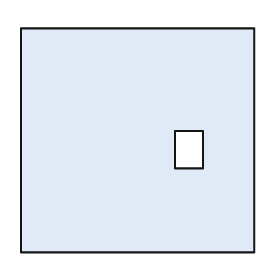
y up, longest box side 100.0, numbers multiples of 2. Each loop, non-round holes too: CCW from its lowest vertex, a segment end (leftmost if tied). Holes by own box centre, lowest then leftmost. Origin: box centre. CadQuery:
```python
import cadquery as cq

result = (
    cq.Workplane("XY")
    .moveTo(-50.0, -48.0)
    .lineTo(50.0, -48.0)
    .lineTo(50.0, 48.0)
    .lineTo(-50.0, 48.0)
    .close()
    .moveTo(16.0, -12.0)
    .lineTo(28.0, -12.0)
    .lineTo(28.0, 4.0)
    .lineTo(16.0, 4.0)
    .close()
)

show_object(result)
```